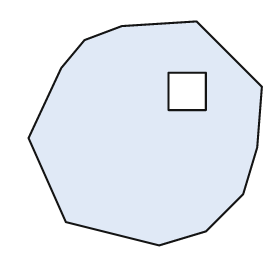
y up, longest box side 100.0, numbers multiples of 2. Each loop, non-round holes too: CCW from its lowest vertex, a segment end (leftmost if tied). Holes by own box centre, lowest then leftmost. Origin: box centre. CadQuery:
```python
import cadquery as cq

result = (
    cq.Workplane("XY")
    .moveTo(6.0, -48.0)
    .lineTo(26.0, -42.0)
    .lineTo(42.0, -26.0)
    .lineTo(48.0, -6.0)
    .lineTo(50.0, 20.0)
    .lineTo(22.0, 48.0)
    .lineTo(-10.0, 46.0)
    .lineTo(-26.0, 40.0)
    .lineTo(-36.0, 28.0)
    .lineTo(-50.0, -2.0)
    .lineTo(-34.0, -38.0)
    .close()
    .moveTo(10.0, 10.0)
    .lineTo(26.0, 10.0)
    .lineTo(26.0, 26.0)
    .lineTo(10.0, 26.0)
    .close()
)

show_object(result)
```